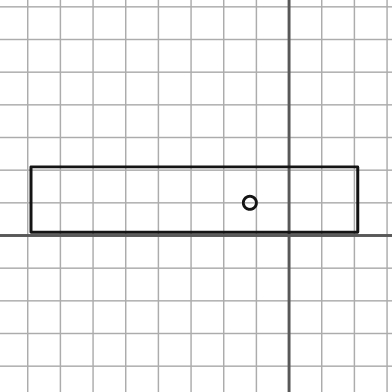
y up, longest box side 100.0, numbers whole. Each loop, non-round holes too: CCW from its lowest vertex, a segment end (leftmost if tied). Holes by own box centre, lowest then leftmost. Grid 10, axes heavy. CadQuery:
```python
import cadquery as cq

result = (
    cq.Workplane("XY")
    .moveTo(-79.0, 1.0)
    .lineTo(21.0, 1.0)
    .lineTo(21.0, 21.0)
    .lineTo(-79.0, 21.0)
    .close()
    .moveTo(-12.0, 10.0)
    .circle(2.0)
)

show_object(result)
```